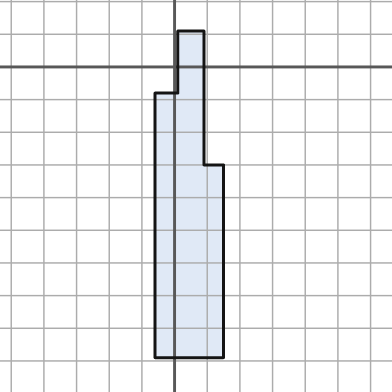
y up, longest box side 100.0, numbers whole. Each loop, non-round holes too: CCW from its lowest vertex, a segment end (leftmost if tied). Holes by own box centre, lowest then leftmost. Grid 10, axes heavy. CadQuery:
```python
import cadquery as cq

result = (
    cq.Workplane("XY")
    .moveTo(-6.0, -89.0)
    .lineTo(15.0, -89.0)
    .lineTo(15.0, -30.0)
    .lineTo(9.0, -30.0)
    .lineTo(9.0, 11.0)
    .lineTo(1.0, 11.0)
    .lineTo(1.0, -8.0)
    .lineTo(-6.0, -8.0)
    .close()
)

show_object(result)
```